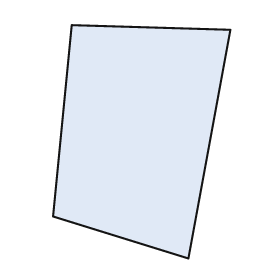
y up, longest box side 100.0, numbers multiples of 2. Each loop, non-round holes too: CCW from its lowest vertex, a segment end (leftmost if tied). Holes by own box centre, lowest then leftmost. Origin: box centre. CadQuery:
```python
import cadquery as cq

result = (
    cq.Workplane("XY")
    .moveTo(20.0, -50.0)
    .lineTo(38.0, 48.0)
    .lineTo(-30.0, 50.0)
    .lineTo(-38.0, -32.0)
    .close()
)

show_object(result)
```